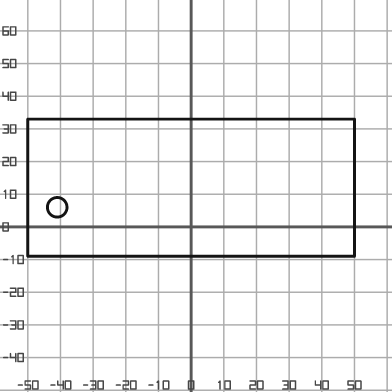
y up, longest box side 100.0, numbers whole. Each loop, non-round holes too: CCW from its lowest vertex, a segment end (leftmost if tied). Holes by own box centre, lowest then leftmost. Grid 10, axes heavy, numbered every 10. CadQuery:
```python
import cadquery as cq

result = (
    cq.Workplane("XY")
    .moveTo(-50.0, -9.0)
    .lineTo(50.0, -9.0)
    .lineTo(50.0, 33.0)
    .lineTo(-50.0, 33.0)
    .close()
    .moveTo(-41.0, 6.0)
    .circle(3.0)
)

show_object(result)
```